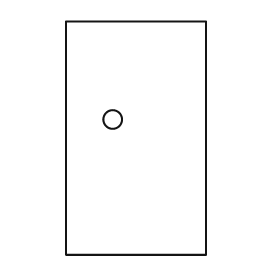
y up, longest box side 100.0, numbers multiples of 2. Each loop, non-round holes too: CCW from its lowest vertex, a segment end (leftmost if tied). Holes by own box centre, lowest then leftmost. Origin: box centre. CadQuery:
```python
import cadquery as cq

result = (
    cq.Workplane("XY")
    .moveTo(-30.0, -50.0)
    .lineTo(30.0, -50.0)
    .lineTo(30.0, 50.0)
    .lineTo(-30.0, 50.0)
    .close()
    .moveTo(-10.0, 8.0)
    .circle(4.0)
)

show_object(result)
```